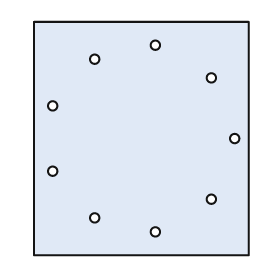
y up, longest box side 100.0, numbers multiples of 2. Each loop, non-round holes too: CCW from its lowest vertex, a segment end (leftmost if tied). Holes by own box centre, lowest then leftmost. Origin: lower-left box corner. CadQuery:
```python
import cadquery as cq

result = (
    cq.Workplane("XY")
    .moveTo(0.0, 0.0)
    .lineTo(92.0, 0.0)
    .lineTo(92.0, 100.0)
    .lineTo(0.0, 100.0)
    .close()
    .moveTo(52.0, 10.0)
    .circle(2.0)
    .moveTo(26.0, 16.0)
    .circle(2.0)
    .moveTo(76.0, 24.0)
    .circle(2.0)
    .moveTo(8.0, 36.0)
    .circle(2.0)
    .moveTo(86.0, 50.0)
    .circle(2.0)
    .moveTo(8.0, 64.0)
    .circle(2.0)
    .moveTo(76.0, 76.0)
    .circle(2.0)
    .moveTo(26.0, 84.0)
    .circle(2.0)
    .moveTo(52.0, 90.0)
    .circle(2.0)
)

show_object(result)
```